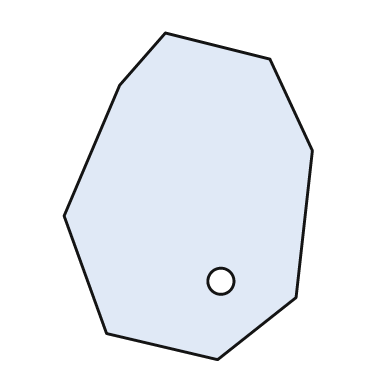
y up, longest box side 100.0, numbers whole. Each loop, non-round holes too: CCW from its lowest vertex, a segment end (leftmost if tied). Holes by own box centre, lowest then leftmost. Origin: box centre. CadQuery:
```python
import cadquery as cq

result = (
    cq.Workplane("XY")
    .moveTo(9.0, -50.0)
    .lineTo(33.0, -31.0)
    .lineTo(38.0, 14.0)
    .lineTo(25.0, 42.0)
    .lineTo(-7.0, 50.0)
    .lineTo(-21.0, 34.0)
    .lineTo(-38.0, -6.0)
    .lineTo(-25.0, -42.0)
    .close()
    .moveTo(10.0, -26.0)
    .circle(4.0)
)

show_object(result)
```